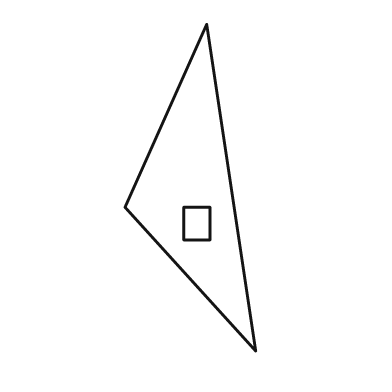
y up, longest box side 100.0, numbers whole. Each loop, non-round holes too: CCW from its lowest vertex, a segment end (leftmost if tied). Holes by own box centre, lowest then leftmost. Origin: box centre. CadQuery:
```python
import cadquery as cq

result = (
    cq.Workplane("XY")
    .moveTo(20.0, -50.0)
    .lineTo(5.0, 50.0)
    .lineTo(-20.0, -6.0)
    .close()
    .moveTo(-2.0, -16.0)
    .lineTo(6.0, -16.0)
    .lineTo(6.0, -6.0)
    .lineTo(-2.0, -6.0)
    .close()
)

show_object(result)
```